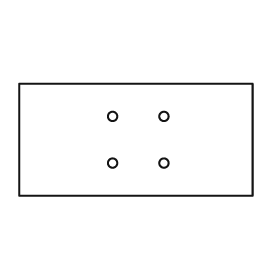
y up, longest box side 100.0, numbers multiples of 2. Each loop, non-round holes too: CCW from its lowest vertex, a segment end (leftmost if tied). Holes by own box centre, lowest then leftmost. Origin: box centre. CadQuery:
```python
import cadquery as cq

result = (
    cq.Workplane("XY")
    .moveTo(-50.0, -24.0)
    .lineTo(50.0, -24.0)
    .lineTo(50.0, 24.0)
    .lineTo(-50.0, 24.0)
    .close()
    .moveTo(-10.0, -10.0)
    .circle(2.0)
    .moveTo(12.0, -10.0)
    .circle(2.0)
    .moveTo(-10.0, 10.0)
    .circle(2.0)
    .moveTo(12.0, 10.0)
    .circle(2.0)
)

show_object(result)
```